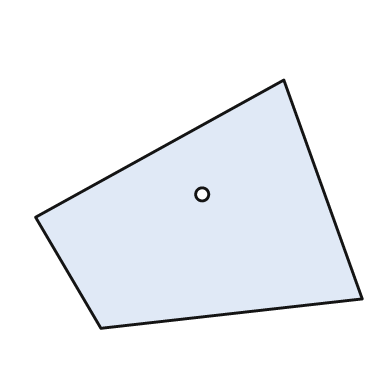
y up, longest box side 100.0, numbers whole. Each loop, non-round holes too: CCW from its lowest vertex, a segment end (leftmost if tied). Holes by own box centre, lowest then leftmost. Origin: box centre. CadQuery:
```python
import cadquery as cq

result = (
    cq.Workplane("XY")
    .moveTo(-30.0, -38.0)
    .lineTo(50.0, -29.0)
    .lineTo(26.0, 38.0)
    .lineTo(-50.0, -4.0)
    .close()
    .moveTo(1.0, 3.0)
    .circle(2.0)
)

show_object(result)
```